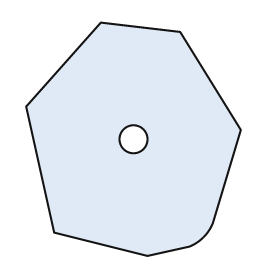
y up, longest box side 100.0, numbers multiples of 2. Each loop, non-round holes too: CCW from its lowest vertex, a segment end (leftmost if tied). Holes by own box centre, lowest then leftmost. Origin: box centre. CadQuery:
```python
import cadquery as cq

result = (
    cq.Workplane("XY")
    .moveTo(6.0, -50.0)
    .lineTo(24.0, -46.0)
    .threePointArc((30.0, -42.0), (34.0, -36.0))
    .lineTo(46.0, 4.0)
    .lineTo(20.0, 46.0)
    .lineTo(-14.0, 50.0)
    .lineTo(-46.0, 14.0)
    .lineTo(-34.0, -40.0)
    .close()
    .moveTo(0.0, 0.0)
    .circle(6.0)
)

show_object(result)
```